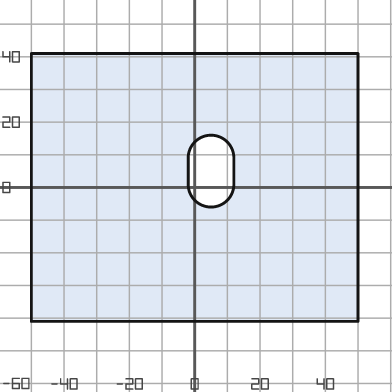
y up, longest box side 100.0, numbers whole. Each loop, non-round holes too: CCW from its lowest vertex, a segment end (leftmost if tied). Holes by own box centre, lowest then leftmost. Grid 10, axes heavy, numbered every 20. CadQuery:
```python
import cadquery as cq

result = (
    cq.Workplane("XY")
    .moveTo(-50.0, -41.0)
    .lineTo(50.0, -41.0)
    .lineTo(50.0, 41.0)
    .lineTo(-50.0, 41.0)
    .close()
    .moveTo(-2.0, 1.0)
    .threePointArc((5.0, -6.0), (12.0, 1.0))
    .lineTo(12.0, 9.0)
    .threePointArc((5.0, 16.0), (-2.0, 9.0))
    .close()
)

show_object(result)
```